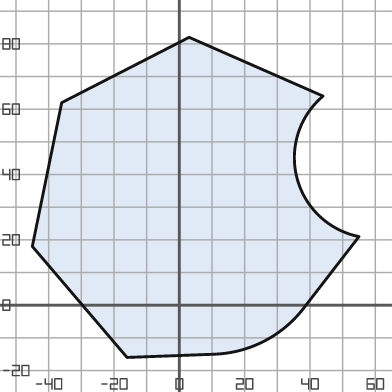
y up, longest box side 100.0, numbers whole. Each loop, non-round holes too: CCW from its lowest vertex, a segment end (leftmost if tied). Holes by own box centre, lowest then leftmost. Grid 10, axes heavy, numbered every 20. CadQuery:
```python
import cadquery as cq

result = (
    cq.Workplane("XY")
    .moveTo(-16.0, -16.0)
    .lineTo(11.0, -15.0)
    .threePointArc((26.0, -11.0), (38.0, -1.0))
    .lineTo(55.0, 21.0)
    .threePointArc((36.0, 39.0), (44.0, 64.0))
    .lineTo(3.0, 82.0)
    .lineTo(-36.0, 62.0)
    .lineTo(-45.0, 18.0)
    .close()
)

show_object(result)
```